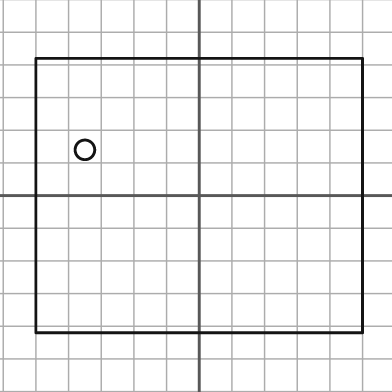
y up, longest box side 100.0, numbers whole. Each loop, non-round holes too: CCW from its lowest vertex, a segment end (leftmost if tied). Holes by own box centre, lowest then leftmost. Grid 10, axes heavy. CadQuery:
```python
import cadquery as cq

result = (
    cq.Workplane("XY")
    .moveTo(-50.0, -42.0)
    .lineTo(50.0, -42.0)
    .lineTo(50.0, 42.0)
    .lineTo(-50.0, 42.0)
    .close()
    .moveTo(-35.0, 14.0)
    .circle(3.0)
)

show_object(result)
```